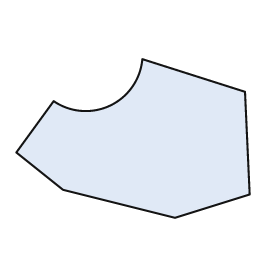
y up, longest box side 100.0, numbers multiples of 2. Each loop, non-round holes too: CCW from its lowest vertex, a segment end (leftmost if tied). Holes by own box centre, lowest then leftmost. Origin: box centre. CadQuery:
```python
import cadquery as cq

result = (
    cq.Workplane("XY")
    .moveTo(18.0, -34.0)
    .lineTo(50.0, -24.0)
    .lineTo(48.0, 20.0)
    .lineTo(4.0, 34.0)
    .threePointArc((-10.0, 14.0), (-34.0, 16.0))
    .lineTo(-50.0, -6.0)
    .lineTo(-30.0, -22.0)
    .close()
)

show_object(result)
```